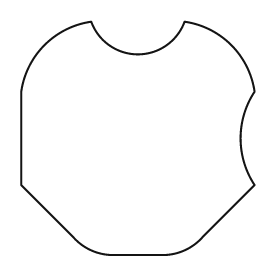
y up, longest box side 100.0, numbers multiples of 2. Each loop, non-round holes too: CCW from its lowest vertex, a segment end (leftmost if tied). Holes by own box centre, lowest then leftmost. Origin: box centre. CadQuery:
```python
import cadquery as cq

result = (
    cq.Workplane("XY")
    .moveTo(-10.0, -50.0)
    .lineTo(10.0, -50.0)
    .threePointArc((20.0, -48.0), (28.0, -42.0))
    .lineTo(50.0, -20.0)
    .threePointArc((44.0, 0.0), (50.0, 20.0))
    .threePointArc((40.0, 40.0), (20.0, 50.0))
    .threePointArc((0.0, 36.0), (-20.0, 50.0))
    .threePointArc((-40.0, 40.0), (-50.0, 20.0))
    .lineTo(-50.0, -20.0)
    .lineTo(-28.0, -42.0)
    .threePointArc((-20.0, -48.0), (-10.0, -50.0))
    .close()
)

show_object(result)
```